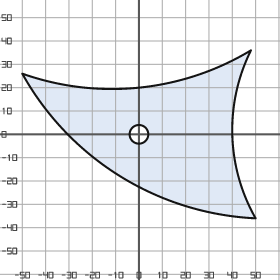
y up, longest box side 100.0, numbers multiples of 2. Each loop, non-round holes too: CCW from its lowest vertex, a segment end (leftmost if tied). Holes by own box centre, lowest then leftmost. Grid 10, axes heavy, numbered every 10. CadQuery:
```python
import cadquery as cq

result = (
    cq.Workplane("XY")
    .moveTo(50.0, -36.0)
    .threePointArc((40.0, 0.0), (48.0, 36.0))
    .threePointArc((0.0, 20.0), (-50.0, 26.0))
    .threePointArc((-8.0, -18.0), (50.0, -36.0))
    .close()
    .moveTo(0.0, 0.0)
    .circle(4.0)
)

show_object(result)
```